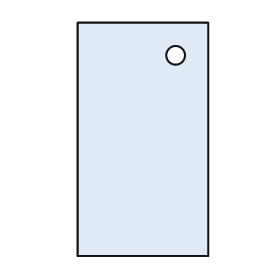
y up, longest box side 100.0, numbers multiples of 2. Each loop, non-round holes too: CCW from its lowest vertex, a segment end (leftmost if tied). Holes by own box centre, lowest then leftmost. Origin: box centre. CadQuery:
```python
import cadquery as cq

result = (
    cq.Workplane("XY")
    .moveTo(-28.0, -50.0)
    .lineTo(28.0, -50.0)
    .lineTo(28.0, 50.0)
    .lineTo(-28.0, 50.0)
    .close()
    .moveTo(14.0, 36.0)
    .circle(4.0)
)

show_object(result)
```